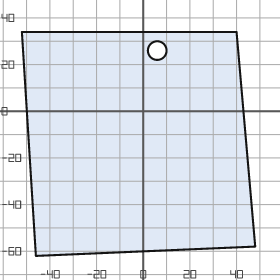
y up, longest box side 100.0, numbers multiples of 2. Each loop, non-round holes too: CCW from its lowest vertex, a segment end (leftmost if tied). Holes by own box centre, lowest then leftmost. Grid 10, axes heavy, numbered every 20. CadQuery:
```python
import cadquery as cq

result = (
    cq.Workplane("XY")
    .moveTo(-46.0, -62.0)
    .lineTo(48.0, -58.0)
    .lineTo(40.0, 34.0)
    .lineTo(-52.0, 34.0)
    .close()
    .moveTo(6.0, 26.0)
    .circle(4.0)
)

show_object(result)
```